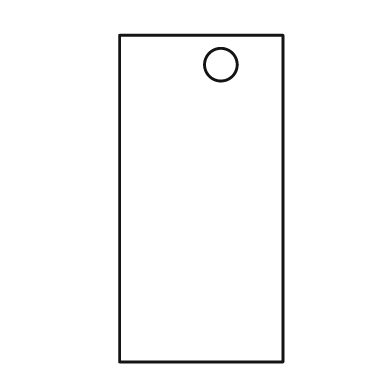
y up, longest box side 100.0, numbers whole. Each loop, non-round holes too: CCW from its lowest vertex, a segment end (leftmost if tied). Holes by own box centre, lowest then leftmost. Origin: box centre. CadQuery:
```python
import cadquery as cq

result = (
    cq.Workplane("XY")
    .moveTo(-25.0, -50.0)
    .lineTo(25.0, -50.0)
    .lineTo(25.0, 50.0)
    .lineTo(-25.0, 50.0)
    .close()
    .moveTo(6.0, 41.0)
    .circle(5.0)
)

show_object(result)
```